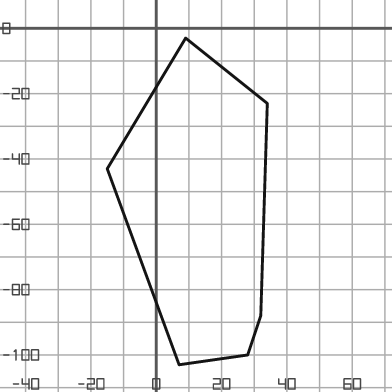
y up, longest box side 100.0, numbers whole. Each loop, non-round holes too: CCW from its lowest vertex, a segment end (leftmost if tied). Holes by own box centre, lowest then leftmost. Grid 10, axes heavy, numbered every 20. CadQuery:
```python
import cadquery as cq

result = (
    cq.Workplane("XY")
    .moveTo(7.0, -103.0)
    .lineTo(28.0, -100.0)
    .lineTo(32.0, -88.0)
    .lineTo(34.0, -23.0)
    .lineTo(9.0, -3.0)
    .lineTo(-15.0, -43.0)
    .close()
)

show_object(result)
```